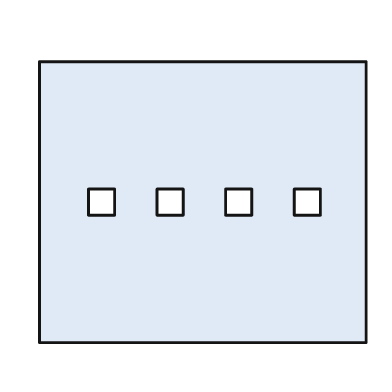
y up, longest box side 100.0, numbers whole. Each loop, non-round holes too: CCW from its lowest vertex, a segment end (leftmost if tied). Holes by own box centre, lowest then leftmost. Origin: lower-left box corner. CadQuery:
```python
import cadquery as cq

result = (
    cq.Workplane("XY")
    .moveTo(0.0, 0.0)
    .lineTo(100.0, 0.0)
    .lineTo(100.0, 86.0)
    .lineTo(0.0, 86.0)
    .close()
    .moveTo(15.0, 39.0)
    .lineTo(23.0, 39.0)
    .lineTo(23.0, 47.0)
    .lineTo(15.0, 47.0)
    .close()
    .moveTo(36.0, 39.0)
    .lineTo(44.0, 39.0)
    .lineTo(44.0, 47.0)
    .lineTo(36.0, 47.0)
    .close()
    .moveTo(57.0, 39.0)
    .lineTo(65.0, 39.0)
    .lineTo(65.0, 47.0)
    .lineTo(57.0, 47.0)
    .close()
    .moveTo(78.0, 39.0)
    .lineTo(86.0, 39.0)
    .lineTo(86.0, 47.0)
    .lineTo(78.0, 47.0)
    .close()
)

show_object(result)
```